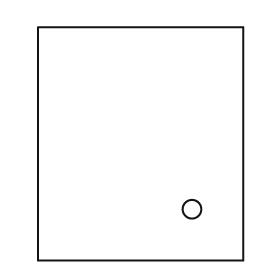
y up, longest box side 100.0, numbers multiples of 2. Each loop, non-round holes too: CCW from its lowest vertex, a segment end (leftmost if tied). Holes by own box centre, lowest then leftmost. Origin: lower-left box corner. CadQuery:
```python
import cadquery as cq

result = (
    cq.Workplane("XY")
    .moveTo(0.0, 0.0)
    .lineTo(88.0, 0.0)
    .lineTo(88.0, 100.0)
    .lineTo(0.0, 100.0)
    .close()
    .moveTo(66.0, 22.0)
    .circle(4.0)
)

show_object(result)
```